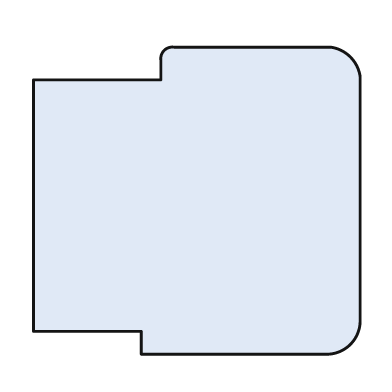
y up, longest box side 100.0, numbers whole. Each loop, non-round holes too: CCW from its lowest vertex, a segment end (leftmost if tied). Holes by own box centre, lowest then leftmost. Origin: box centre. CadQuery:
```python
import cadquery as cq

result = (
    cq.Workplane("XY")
    .moveTo(-17.0, -47.0)
    .lineTo(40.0, -47.0)
    .threePointArc((47.0, -44.0), (50.0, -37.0))
    .lineTo(50.0, 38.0)
    .threePointArc((47.0, 44.0), (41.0, 47.0))
    .lineTo(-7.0, 47.0)
    .threePointArc((-10.0, 46.0), (-11.0, 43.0))
    .lineTo(-11.0, 37.0)
    .lineTo(-50.0, 37.0)
    .lineTo(-50.0, -40.0)
    .lineTo(-17.0, -40.0)
    .close()
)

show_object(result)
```